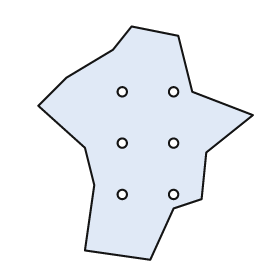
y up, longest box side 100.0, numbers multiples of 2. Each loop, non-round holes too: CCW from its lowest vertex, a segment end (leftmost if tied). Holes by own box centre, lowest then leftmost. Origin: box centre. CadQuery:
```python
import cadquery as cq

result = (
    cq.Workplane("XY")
    .moveTo(2.0, -50.0)
    .lineTo(12.0, -28.0)
    .lineTo(24.0, -24.0)
    .lineTo(26.0, -4.0)
    .lineTo(46.0, 12.0)
    .lineTo(20.0, 22.0)
    .lineTo(14.0, 46.0)
    .lineTo(-6.0, 50.0)
    .lineTo(-14.0, 40.0)
    .lineTo(-34.0, 28.0)
    .lineTo(-46.0, 16.0)
    .lineTo(-26.0, -2.0)
    .lineTo(-22.0, -18.0)
    .lineTo(-26.0, -46.0)
    .close()
    .moveTo(-10.0, -22.0)
    .circle(2.0)
    .moveTo(12.0, -22.0)
    .circle(2.0)
    .moveTo(-10.0, 0.0)
    .circle(2.0)
    .moveTo(12.0, 0.0)
    .circle(2.0)
    .moveTo(-10.0, 22.0)
    .circle(2.0)
    .moveTo(12.0, 22.0)
    .circle(2.0)
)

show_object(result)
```